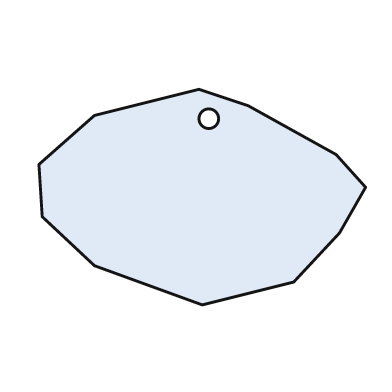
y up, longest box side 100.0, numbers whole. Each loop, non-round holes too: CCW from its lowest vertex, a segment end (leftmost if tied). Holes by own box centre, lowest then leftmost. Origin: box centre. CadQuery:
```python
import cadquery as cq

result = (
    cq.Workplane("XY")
    .moveTo(0.0, -33.0)
    .lineTo(28.0, -26.0)
    .lineTo(42.0, -11.0)
    .lineTo(50.0, 3.0)
    .lineTo(41.0, 13.0)
    .lineTo(14.0, 28.0)
    .lineTo(-1.0, 33.0)
    .lineTo(-33.0, 25.0)
    .lineTo(-50.0, 10.0)
    .lineTo(-49.0, -6.0)
    .lineTo(-33.0, -21.0)
    .close()
    .moveTo(2.0, 24.0)
    .circle(3.0)
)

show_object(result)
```